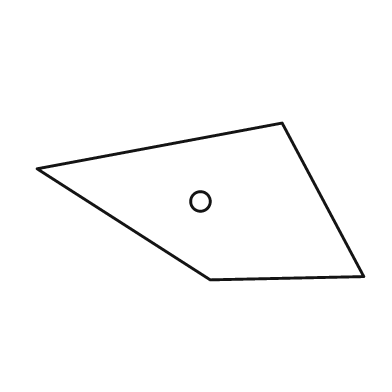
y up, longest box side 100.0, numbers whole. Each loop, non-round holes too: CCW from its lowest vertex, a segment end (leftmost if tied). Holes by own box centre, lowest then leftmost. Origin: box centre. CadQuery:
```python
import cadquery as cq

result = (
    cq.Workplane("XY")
    .moveTo(3.0, -24.0)
    .lineTo(50.0, -23.0)
    .lineTo(25.0, 24.0)
    .lineTo(-50.0, 10.0)
    .close()
    .moveTo(0.0, 0.0)
    .circle(3.0)
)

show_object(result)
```